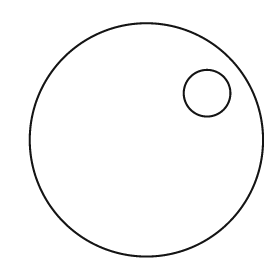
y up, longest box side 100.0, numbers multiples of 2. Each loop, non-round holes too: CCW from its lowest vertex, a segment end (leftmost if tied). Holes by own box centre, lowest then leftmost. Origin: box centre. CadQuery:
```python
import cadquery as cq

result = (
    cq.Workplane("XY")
    .moveTo(0.0, 0.0)
    .circle(50.0)
    .moveTo(26.0, 20.0)
    .circle(10.0)
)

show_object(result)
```